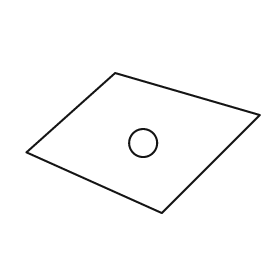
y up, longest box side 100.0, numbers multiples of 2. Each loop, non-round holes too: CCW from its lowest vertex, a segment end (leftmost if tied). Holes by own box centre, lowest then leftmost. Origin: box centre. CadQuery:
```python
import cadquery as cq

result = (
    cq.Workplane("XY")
    .moveTo(8.0, -30.0)
    .lineTo(50.0, 12.0)
    .lineTo(-12.0, 30.0)
    .lineTo(-50.0, -4.0)
    .close()
    .moveTo(0.0, 0.0)
    .circle(6.0)
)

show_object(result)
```